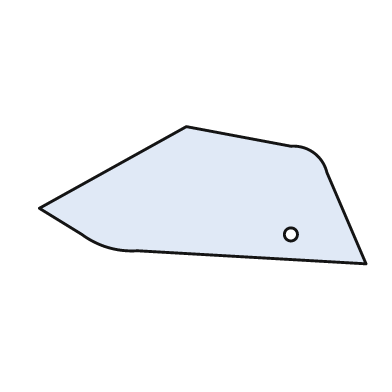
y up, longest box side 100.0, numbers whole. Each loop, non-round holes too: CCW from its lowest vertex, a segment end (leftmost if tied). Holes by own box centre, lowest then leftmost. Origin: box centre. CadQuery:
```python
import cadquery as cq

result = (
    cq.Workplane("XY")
    .moveTo(50.0, -21.0)
    .lineTo(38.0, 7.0)
    .threePointArc((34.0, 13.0), (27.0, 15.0))
    .lineTo(-5.0, 21.0)
    .lineTo(-50.0, -4.0)
    .lineTo(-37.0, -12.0)
    .threePointArc((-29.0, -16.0), (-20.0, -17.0))
    .close()
    .moveTo(27.0, -12.0)
    .circle(2.0)
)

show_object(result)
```